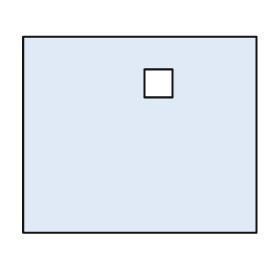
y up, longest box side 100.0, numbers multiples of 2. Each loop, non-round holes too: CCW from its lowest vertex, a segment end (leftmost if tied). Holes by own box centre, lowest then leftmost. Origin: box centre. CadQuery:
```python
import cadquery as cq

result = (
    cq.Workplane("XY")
    .moveTo(-50.0, -42.0)
    .lineTo(50.0, -42.0)
    .lineTo(50.0, 42.0)
    .lineTo(-50.0, 42.0)
    .close()
    .moveTo(2.0, 16.0)
    .lineTo(14.0, 16.0)
    .lineTo(14.0, 28.0)
    .lineTo(2.0, 28.0)
    .close()
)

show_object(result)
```